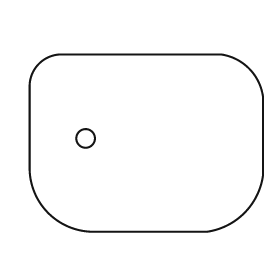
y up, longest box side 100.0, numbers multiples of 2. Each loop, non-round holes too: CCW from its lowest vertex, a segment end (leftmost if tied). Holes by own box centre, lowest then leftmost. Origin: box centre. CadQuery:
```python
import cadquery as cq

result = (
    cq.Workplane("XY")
    .moveTo(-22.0, -38.0)
    .lineTo(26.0, -38.0)
    .threePointArc((42.0, -30.0), (50.0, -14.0))
    .lineTo(50.0, 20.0)
    .threePointArc((44.0, 32.0), (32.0, 38.0))
    .lineTo(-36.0, 38.0)
    .threePointArc((-46.0, 34.0), (-50.0, 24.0))
    .lineTo(-50.0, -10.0)
    .threePointArc((-42.0, -30.0), (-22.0, -38.0))
    .close()
    .moveTo(-26.0, 2.0)
    .circle(4.0)
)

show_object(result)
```